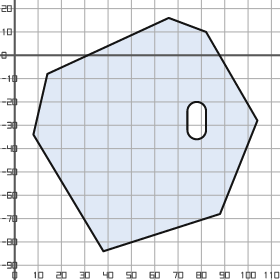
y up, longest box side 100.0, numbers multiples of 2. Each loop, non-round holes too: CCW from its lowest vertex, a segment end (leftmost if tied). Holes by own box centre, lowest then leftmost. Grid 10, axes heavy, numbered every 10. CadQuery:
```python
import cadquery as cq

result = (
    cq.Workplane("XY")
    .moveTo(38.0, -84.0)
    .lineTo(88.0, -68.0)
    .lineTo(104.0, -28.0)
    .lineTo(82.0, 10.0)
    .lineTo(66.0, 16.0)
    .lineTo(14.0, -8.0)
    .lineTo(8.0, -34.0)
    .close()
    .moveTo(74.0, -32.0)
    .threePointArc((78.0, -36.0), (82.0, -32.0))
    .lineTo(82.0, -24.0)
    .threePointArc((78.0, -20.0), (74.0, -24.0))
    .close()
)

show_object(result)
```